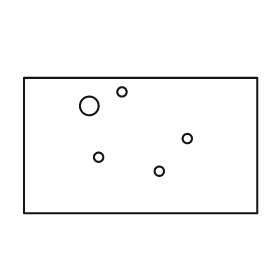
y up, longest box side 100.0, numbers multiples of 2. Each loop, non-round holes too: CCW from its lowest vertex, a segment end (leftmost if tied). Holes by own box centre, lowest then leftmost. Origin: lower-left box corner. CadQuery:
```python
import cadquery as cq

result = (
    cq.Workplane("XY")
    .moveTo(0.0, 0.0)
    .lineTo(100.0, 0.0)
    .lineTo(100.0, 58.0)
    .lineTo(0.0, 58.0)
    .close()
    .moveTo(58.0, 18.0)
    .circle(2.0)
    .moveTo(32.0, 24.0)
    .circle(2.0)
    .moveTo(70.0, 32.0)
    .circle(2.0)
    .moveTo(28.0, 46.0)
    .circle(4.0)
    .moveTo(42.0, 52.0)
    .circle(2.0)
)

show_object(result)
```